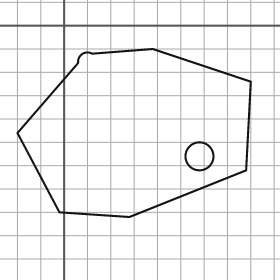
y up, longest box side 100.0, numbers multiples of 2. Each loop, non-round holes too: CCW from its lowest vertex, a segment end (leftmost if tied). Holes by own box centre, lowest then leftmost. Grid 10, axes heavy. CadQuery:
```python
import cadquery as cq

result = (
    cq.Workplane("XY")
    .moveTo(28.0, -82.0)
    .lineTo(78.0, -62.0)
    .lineTo(80.0, -24.0)
    .lineTo(38.0, -10.0)
    .lineTo(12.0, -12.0)
    .threePointArc((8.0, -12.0), (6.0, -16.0))
    .lineTo(-20.0, -46.0)
    .lineTo(-2.0, -80.0)
    .close()
    .moveTo(58.0, -56.0)
    .circle(6.0)
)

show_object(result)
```